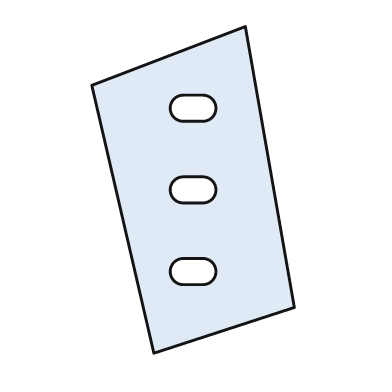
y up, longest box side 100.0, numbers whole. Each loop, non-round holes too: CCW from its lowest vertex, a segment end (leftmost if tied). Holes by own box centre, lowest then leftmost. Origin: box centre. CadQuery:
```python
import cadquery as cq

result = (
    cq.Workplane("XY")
    .moveTo(-12.0, -50.0)
    .lineTo(31.0, -36.0)
    .lineTo(16.0, 50.0)
    .lineTo(-31.0, 32.0)
    .close()
    .moveTo(-3.0, -29.0)
    .lineTo(3.0, -29.0)
    .threePointArc((7.0, -25.0), (3.0, -21.0))
    .lineTo(-3.0, -21.0)
    .threePointArc((-7.0, -25.0), (-3.0, -29.0))
    .close()
    .moveTo(-3.0, -4.0)
    .lineTo(3.0, -4.0)
    .threePointArc((7.0, 0.0), (3.0, 4.0))
    .lineTo(-3.0, 4.0)
    .threePointArc((-7.0, 0.0), (-3.0, -4.0))
    .close()
    .moveTo(-3.0, 21.0)
    .lineTo(3.0, 21.0)
    .threePointArc((7.0, 25.0), (3.0, 29.0))
    .lineTo(-3.0, 29.0)
    .threePointArc((-7.0, 25.0), (-3.0, 21.0))
    .close()
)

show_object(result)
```